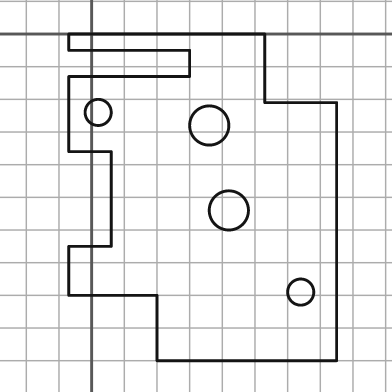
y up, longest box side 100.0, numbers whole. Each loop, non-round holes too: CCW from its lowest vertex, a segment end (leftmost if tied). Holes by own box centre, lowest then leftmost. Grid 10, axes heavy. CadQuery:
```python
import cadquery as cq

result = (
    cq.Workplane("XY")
    .moveTo(20.0, -100.0)
    .lineTo(75.0, -100.0)
    .lineTo(75.0, -21.0)
    .lineTo(53.0, -21.0)
    .lineTo(53.0, 0.0)
    .lineTo(-7.0, 0.0)
    .lineTo(-7.0, -5.0)
    .lineTo(30.0, -5.0)
    .lineTo(30.0, -13.0)
    .lineTo(-7.0, -13.0)
    .lineTo(-7.0, -36.0)
    .lineTo(6.0, -36.0)
    .lineTo(6.0, -65.0)
    .lineTo(-7.0, -65.0)
    .lineTo(-7.0, -80.0)
    .lineTo(20.0, -80.0)
    .close()
    .moveTo(64.0, -79.0)
    .circle(4.0)
    .moveTo(42.0, -54.0)
    .circle(6.0)
    .moveTo(36.0, -28.0)
    .circle(6.0)
    .moveTo(2.0, -24.0)
    .circle(4.0)
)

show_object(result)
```